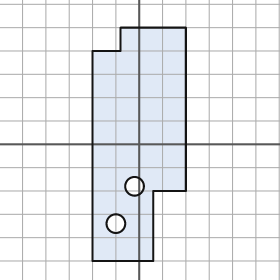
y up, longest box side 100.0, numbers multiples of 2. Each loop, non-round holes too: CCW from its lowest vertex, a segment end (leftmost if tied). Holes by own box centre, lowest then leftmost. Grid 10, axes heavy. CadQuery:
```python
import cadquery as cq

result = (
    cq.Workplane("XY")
    .moveTo(-20.0, -50.0)
    .lineTo(6.0, -50.0)
    .lineTo(6.0, -20.0)
    .lineTo(20.0, -20.0)
    .lineTo(20.0, 50.0)
    .lineTo(-8.0, 50.0)
    .lineTo(-8.0, 40.0)
    .lineTo(-20.0, 40.0)
    .close()
    .moveTo(-10.0, -34.0)
    .circle(4.0)
    .moveTo(-2.0, -18.0)
    .circle(4.0)
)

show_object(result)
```